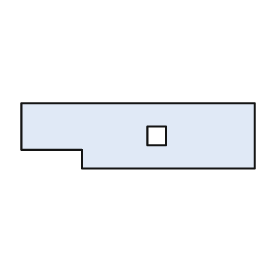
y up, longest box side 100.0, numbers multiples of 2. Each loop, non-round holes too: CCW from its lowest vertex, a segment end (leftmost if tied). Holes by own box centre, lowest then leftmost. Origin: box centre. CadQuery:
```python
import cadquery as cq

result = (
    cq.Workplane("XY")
    .moveTo(-24.0, -14.0)
    .lineTo(50.0, -14.0)
    .lineTo(50.0, 14.0)
    .lineTo(-50.0, 14.0)
    .lineTo(-50.0, -6.0)
    .lineTo(-24.0, -6.0)
    .close()
    .moveTo(4.0, -4.0)
    .lineTo(12.0, -4.0)
    .lineTo(12.0, 4.0)
    .lineTo(4.0, 4.0)
    .close()
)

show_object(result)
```